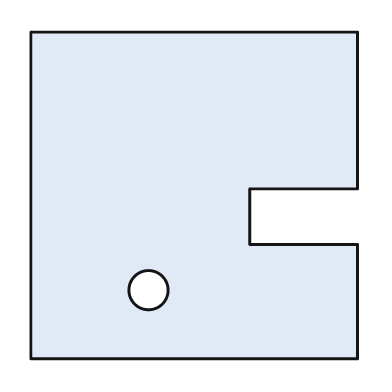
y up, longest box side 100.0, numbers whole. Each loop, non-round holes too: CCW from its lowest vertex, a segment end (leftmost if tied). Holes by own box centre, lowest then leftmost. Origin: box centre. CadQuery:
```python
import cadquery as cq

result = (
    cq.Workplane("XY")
    .moveTo(-50.0, -50.0)
    .lineTo(50.0, -50.0)
    .lineTo(50.0, -15.0)
    .lineTo(17.0, -15.0)
    .lineTo(17.0, 2.0)
    .lineTo(50.0, 2.0)
    .lineTo(50.0, 50.0)
    .lineTo(-50.0, 50.0)
    .close()
    .moveTo(-14.0, -29.0)
    .circle(6.0)
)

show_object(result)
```